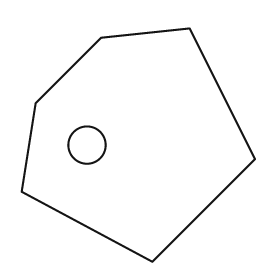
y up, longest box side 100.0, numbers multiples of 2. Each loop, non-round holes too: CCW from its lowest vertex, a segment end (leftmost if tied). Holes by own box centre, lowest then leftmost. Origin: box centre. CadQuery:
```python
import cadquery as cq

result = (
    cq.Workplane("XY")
    .moveTo(6.0, -50.0)
    .lineTo(50.0, -6.0)
    .lineTo(22.0, 50.0)
    .lineTo(-16.0, 46.0)
    .lineTo(-44.0, 18.0)
    .lineTo(-50.0, -20.0)
    .close()
    .moveTo(-22.0, 0.0)
    .circle(8.0)
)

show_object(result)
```